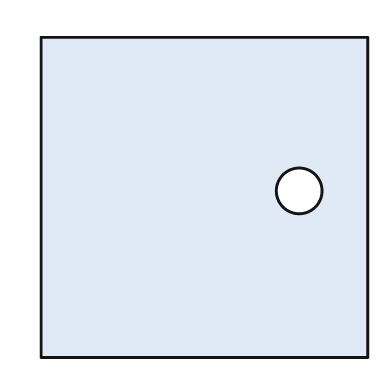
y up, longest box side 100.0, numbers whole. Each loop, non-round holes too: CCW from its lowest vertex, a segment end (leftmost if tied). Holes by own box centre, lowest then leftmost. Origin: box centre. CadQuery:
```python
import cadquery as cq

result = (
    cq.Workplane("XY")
    .moveTo(-50.0, -49.0)
    .lineTo(50.0, -49.0)
    .lineTo(50.0, 49.0)
    .lineTo(-50.0, 49.0)
    .close()
    .moveTo(29.0, 2.0)
    .circle(7.0)
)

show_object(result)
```